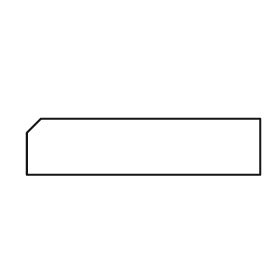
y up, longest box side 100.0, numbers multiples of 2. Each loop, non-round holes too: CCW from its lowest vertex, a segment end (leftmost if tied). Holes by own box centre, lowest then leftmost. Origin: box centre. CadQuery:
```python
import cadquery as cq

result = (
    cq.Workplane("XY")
    .moveTo(-50.0, -12.0)
    .lineTo(50.0, -12.0)
    .lineTo(50.0, 12.0)
    .lineTo(-44.0, 12.0)
    .lineTo(-50.0, 6.0)
    .close()
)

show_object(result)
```